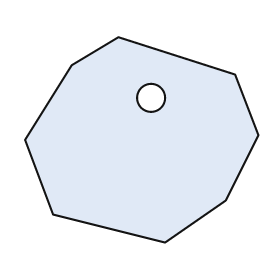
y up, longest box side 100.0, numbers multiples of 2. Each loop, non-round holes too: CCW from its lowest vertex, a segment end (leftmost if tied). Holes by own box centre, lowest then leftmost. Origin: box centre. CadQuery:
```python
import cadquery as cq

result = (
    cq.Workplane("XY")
    .moveTo(10.0, -44.0)
    .lineTo(36.0, -26.0)
    .lineTo(50.0, 2.0)
    .lineTo(40.0, 28.0)
    .lineTo(-10.0, 44.0)
    .lineTo(-30.0, 32.0)
    .lineTo(-50.0, 0.0)
    .lineTo(-38.0, -32.0)
    .close()
    .moveTo(4.0, 18.0)
    .circle(6.0)
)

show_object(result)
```